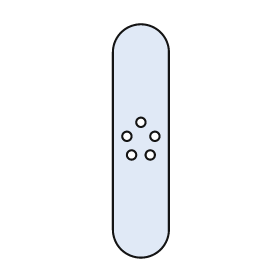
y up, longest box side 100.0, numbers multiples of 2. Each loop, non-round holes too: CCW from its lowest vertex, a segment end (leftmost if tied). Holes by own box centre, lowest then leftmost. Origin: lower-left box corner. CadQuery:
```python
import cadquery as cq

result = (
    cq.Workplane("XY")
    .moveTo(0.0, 12.0)
    .threePointArc((12.0, 0.0), (24.0, 12.0))
    .lineTo(24.0, 88.0)
    .threePointArc((12.0, 100.0), (0.0, 88.0))
    .close()
    .moveTo(8.0, 44.0)
    .circle(2.0)
    .moveTo(16.0, 44.0)
    .circle(2.0)
    .moveTo(6.0, 52.0)
    .circle(2.0)
    .moveTo(18.0, 52.0)
    .circle(2.0)
    .moveTo(12.0, 58.0)
    .circle(2.0)
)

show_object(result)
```